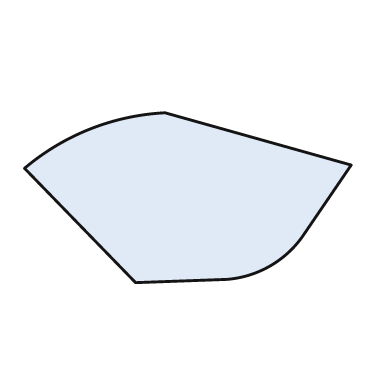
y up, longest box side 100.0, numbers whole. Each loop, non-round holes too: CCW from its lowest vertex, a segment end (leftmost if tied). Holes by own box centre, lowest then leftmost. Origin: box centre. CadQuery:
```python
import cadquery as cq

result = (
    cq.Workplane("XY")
    .moveTo(-16.0, -26.0)
    .lineTo(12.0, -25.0)
    .threePointArc((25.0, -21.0), (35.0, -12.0))
    .lineTo(50.0, 10.0)
    .lineTo(-7.0, 26.0)
    .threePointArc((-30.0, 21.0), (-50.0, 9.0))
    .close()
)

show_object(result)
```